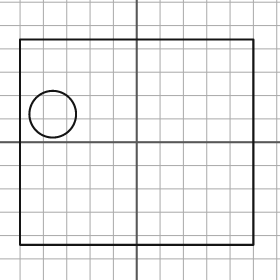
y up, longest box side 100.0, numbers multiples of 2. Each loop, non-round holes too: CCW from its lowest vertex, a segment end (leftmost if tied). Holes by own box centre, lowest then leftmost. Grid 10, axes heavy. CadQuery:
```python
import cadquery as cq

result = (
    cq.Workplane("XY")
    .moveTo(-50.0, -44.0)
    .lineTo(50.0, -44.0)
    .lineTo(50.0, 44.0)
    .lineTo(-50.0, 44.0)
    .close()
    .moveTo(-36.0, 12.0)
    .circle(10.0)
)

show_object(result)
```